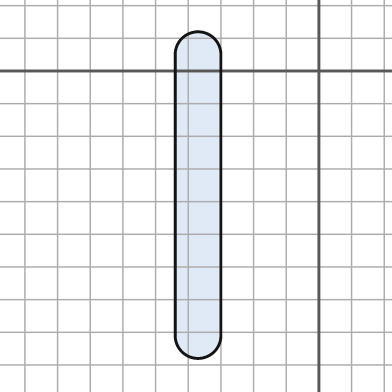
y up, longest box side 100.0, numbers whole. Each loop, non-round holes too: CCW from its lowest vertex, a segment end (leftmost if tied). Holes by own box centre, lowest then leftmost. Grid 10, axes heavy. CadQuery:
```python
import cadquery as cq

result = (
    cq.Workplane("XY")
    .moveTo(-44.0, -81.0)
    .threePointArc((-37.0, -88.0), (-30.0, -81.0))
    .lineTo(-30.0, 5.0)
    .threePointArc((-37.0, 12.0), (-44.0, 5.0))
    .close()
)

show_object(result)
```